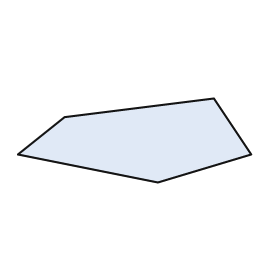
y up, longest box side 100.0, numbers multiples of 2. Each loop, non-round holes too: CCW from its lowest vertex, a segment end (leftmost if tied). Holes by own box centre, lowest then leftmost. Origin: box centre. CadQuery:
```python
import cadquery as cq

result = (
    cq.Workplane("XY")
    .moveTo(10.0, -18.0)
    .lineTo(50.0, -6.0)
    .lineTo(34.0, 18.0)
    .lineTo(-30.0, 10.0)
    .lineTo(-50.0, -6.0)
    .close()
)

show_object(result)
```